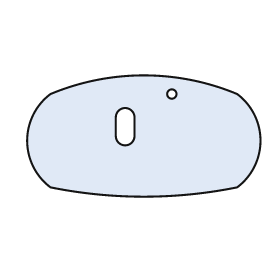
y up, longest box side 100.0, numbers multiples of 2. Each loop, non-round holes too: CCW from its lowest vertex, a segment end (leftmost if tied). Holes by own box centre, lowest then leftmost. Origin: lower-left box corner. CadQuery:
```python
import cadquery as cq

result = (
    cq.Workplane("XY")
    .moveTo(10.0, 4.0)
    .threePointArc((50.0, 0.0), (90.0, 4.0))
    .threePointArc((100.0, 24.0), (90.0, 44.0))
    .threePointArc((50.0, 52.0), (10.0, 44.0))
    .threePointArc((0.0, 24.0), (10.0, 4.0))
    .close()
    .moveTo(38.0, 26.0)
    .threePointArc((42.0, 22.0), (46.0, 26.0))
    .lineTo(46.0, 34.0)
    .threePointArc((42.0, 38.0), (38.0, 34.0))
    .close()
    .moveTo(62.0, 44.0)
    .circle(2.0)
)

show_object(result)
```